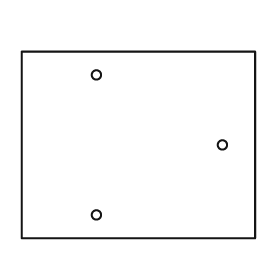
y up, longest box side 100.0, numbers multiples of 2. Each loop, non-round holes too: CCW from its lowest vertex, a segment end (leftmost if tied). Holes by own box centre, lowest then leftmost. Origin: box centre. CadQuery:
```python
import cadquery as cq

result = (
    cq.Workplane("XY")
    .moveTo(-50.0, -40.0)
    .lineTo(50.0, -40.0)
    .lineTo(50.0, 40.0)
    .lineTo(-50.0, 40.0)
    .close()
    .moveTo(-18.0, -30.0)
    .circle(2.0)
    .moveTo(36.0, 0.0)
    .circle(2.0)
    .moveTo(-18.0, 30.0)
    .circle(2.0)
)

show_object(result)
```